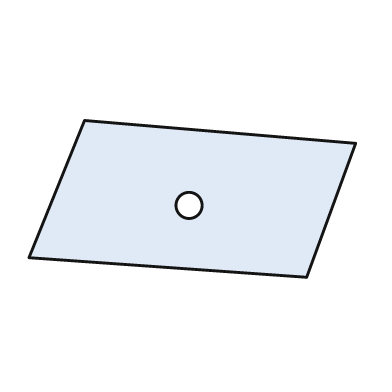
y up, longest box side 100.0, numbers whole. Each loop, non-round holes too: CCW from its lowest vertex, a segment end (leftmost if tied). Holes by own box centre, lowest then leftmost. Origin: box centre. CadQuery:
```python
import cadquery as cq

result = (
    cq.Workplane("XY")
    .moveTo(35.0, -24.0)
    .lineTo(50.0, 17.0)
    .lineTo(-33.0, 24.0)
    .lineTo(-50.0, -18.0)
    .close()
    .moveTo(-1.0, -2.0)
    .circle(4.0)
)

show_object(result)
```